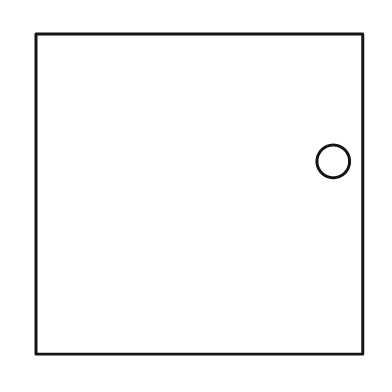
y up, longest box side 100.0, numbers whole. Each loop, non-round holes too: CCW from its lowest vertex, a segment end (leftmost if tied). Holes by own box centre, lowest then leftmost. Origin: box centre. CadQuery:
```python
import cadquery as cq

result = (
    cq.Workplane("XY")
    .moveTo(-50.0, -49.0)
    .lineTo(50.0, -49.0)
    .lineTo(50.0, 49.0)
    .lineTo(-50.0, 49.0)
    .close()
    .moveTo(41.0, 10.0)
    .circle(5.0)
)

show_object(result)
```